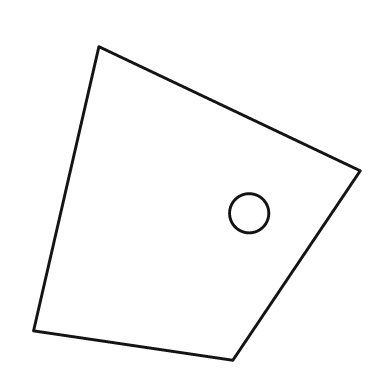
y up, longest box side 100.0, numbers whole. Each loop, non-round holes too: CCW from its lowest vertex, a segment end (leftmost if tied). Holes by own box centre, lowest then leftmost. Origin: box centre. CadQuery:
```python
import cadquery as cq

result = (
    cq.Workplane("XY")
    .moveTo(11.0, -48.0)
    .lineTo(50.0, 10.0)
    .lineTo(-30.0, 48.0)
    .lineTo(-50.0, -39.0)
    .close()
    .moveTo(16.0, -3.0)
    .circle(6.0)
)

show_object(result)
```